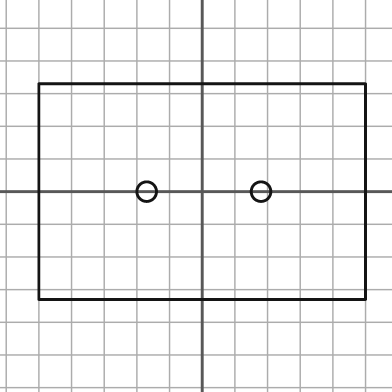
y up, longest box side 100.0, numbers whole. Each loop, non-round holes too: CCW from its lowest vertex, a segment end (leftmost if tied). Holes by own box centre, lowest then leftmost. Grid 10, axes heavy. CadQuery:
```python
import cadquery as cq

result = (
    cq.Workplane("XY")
    .moveTo(-50.0, -33.0)
    .lineTo(50.0, -33.0)
    .lineTo(50.0, 33.0)
    .lineTo(-50.0, 33.0)
    .close()
    .moveTo(-17.0, 0.0)
    .circle(3.0)
    .moveTo(18.0, 0.0)
    .circle(3.0)
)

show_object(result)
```